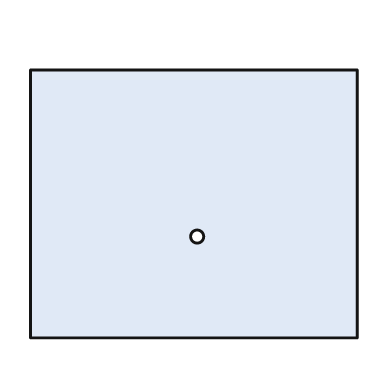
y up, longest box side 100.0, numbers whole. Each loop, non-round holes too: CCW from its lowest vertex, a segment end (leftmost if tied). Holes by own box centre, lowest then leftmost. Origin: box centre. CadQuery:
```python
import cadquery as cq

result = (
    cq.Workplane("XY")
    .moveTo(-50.0, -41.0)
    .lineTo(50.0, -41.0)
    .lineTo(50.0, 41.0)
    .lineTo(-50.0, 41.0)
    .close()
    .moveTo(1.0, -10.0)
    .circle(2.0)
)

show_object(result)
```